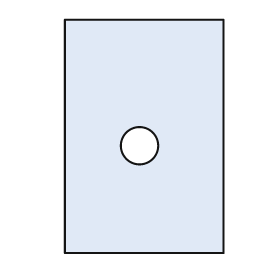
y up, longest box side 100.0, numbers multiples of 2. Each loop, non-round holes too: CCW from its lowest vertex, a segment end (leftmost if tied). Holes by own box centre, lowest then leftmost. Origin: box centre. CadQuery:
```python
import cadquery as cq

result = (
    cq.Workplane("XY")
    .moveTo(-34.0, -50.0)
    .lineTo(34.0, -50.0)
    .lineTo(34.0, 50.0)
    .lineTo(-34.0, 50.0)
    .close()
    .moveTo(-2.0, -4.0)
    .circle(8.0)
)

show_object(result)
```